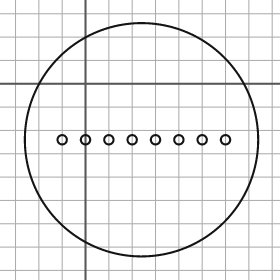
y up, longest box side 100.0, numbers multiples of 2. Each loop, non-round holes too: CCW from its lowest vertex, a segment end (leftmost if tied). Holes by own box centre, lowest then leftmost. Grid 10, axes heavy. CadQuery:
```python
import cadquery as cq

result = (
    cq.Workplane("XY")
    .moveTo(24.0, -24.0)
    .circle(50.0)
    .moveTo(-10.0, -24.0)
    .circle(2.0)
    .moveTo(0.0, -24.0)
    .circle(2.0)
    .moveTo(10.0, -24.0)
    .circle(2.0)
    .moveTo(20.0, -24.0)
    .circle(2.0)
    .moveTo(30.0, -24.0)
    .circle(2.0)
    .moveTo(40.0, -24.0)
    .circle(2.0)
    .moveTo(50.0, -24.0)
    .circle(2.0)
    .moveTo(60.0, -24.0)
    .circle(2.0)
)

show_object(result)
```